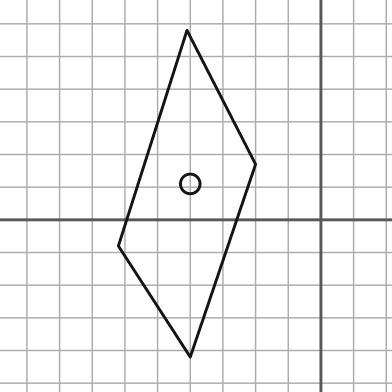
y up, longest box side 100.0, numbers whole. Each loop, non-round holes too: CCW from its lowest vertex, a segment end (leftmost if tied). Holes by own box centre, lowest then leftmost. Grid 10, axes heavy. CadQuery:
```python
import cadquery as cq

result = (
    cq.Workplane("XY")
    .moveTo(-40.0, -42.0)
    .lineTo(-20.0, 17.0)
    .lineTo(-41.0, 58.0)
    .lineTo(-62.0, -8.0)
    .close()
    .moveTo(-40.0, 11.0)
    .circle(3.0)
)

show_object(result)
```